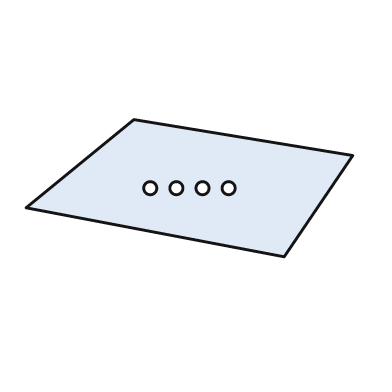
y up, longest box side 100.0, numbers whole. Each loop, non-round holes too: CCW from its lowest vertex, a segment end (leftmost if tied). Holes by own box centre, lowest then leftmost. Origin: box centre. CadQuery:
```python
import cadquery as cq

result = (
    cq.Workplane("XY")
    .moveTo(29.0, -21.0)
    .lineTo(50.0, 10.0)
    .lineTo(-17.0, 21.0)
    .lineTo(-50.0, -6.0)
    .close()
    .moveTo(-12.0, 0.0)
    .circle(2.0)
    .moveTo(-4.0, 0.0)
    .circle(2.0)
    .moveTo(4.0, 0.0)
    .circle(2.0)
    .moveTo(12.0, 0.0)
    .circle(2.0)
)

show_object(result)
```